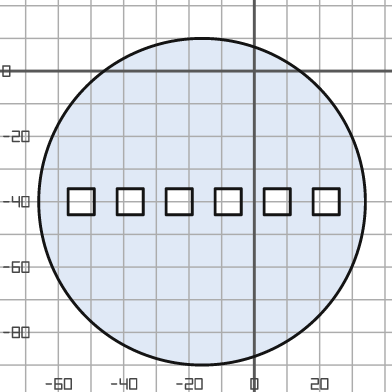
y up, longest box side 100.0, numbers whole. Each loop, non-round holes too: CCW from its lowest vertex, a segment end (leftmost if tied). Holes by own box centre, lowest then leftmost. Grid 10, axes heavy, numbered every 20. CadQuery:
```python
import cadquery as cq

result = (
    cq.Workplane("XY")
    .moveTo(-16.0, -40.0)
    .circle(50.0)
    .moveTo(-57.0, -44.0)
    .lineTo(-49.0, -44.0)
    .lineTo(-49.0, -36.0)
    .lineTo(-57.0, -36.0)
    .close()
    .moveTo(-42.0, -44.0)
    .lineTo(-34.0, -44.0)
    .lineTo(-34.0, -36.0)
    .lineTo(-42.0, -36.0)
    .close()
    .moveTo(-27.0, -44.0)
    .lineTo(-19.0, -44.0)
    .lineTo(-19.0, -36.0)
    .lineTo(-27.0, -36.0)
    .close()
    .moveTo(-12.0, -44.0)
    .lineTo(-4.0, -44.0)
    .lineTo(-4.0, -36.0)
    .lineTo(-12.0, -36.0)
    .close()
    .moveTo(3.0, -44.0)
    .lineTo(11.0, -44.0)
    .lineTo(11.0, -36.0)
    .lineTo(3.0, -36.0)
    .close()
    .moveTo(18.0, -44.0)
    .lineTo(26.0, -44.0)
    .lineTo(26.0, -36.0)
    .lineTo(18.0, -36.0)
    .close()
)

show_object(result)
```